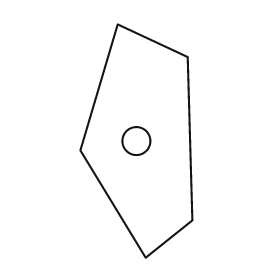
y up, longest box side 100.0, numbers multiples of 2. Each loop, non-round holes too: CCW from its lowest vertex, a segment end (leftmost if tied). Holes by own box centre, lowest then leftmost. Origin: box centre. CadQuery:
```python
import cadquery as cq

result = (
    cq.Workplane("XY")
    .moveTo(4.0, -50.0)
    .lineTo(24.0, -34.0)
    .lineTo(22.0, 36.0)
    .lineTo(-8.0, 50.0)
    .lineTo(-24.0, -4.0)
    .close()
    .moveTo(0.0, 0.0)
    .circle(6.0)
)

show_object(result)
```